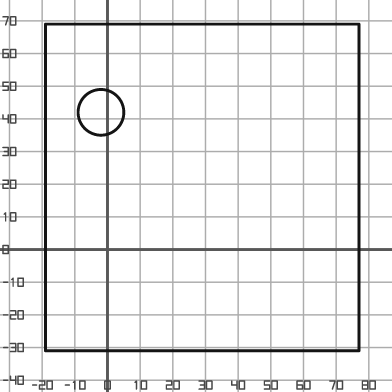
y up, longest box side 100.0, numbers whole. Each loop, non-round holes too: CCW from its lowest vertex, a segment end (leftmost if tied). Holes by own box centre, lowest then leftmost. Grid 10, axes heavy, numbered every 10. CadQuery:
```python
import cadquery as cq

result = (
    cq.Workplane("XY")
    .moveTo(-19.0, -31.0)
    .lineTo(77.0, -31.0)
    .lineTo(77.0, 69.0)
    .lineTo(-19.0, 69.0)
    .close()
    .moveTo(-2.0, 42.0)
    .circle(7.0)
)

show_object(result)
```